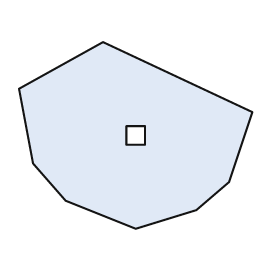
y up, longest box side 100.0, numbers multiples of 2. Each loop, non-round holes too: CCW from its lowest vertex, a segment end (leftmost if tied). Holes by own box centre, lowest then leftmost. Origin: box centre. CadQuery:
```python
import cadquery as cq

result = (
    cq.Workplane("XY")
    .moveTo(0.0, -40.0)
    .lineTo(26.0, -32.0)
    .lineTo(40.0, -20.0)
    .lineTo(50.0, 10.0)
    .lineTo(-14.0, 40.0)
    .lineTo(-50.0, 20.0)
    .lineTo(-44.0, -12.0)
    .lineTo(-30.0, -28.0)
    .close()
    .moveTo(-4.0, -4.0)
    .lineTo(4.0, -4.0)
    .lineTo(4.0, 4.0)
    .lineTo(-4.0, 4.0)
    .close()
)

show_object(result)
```